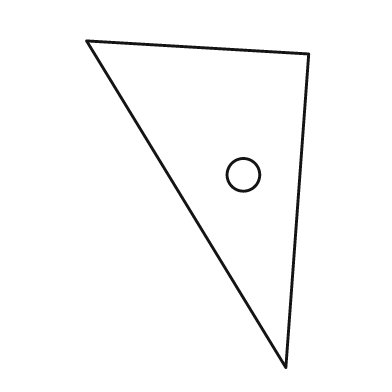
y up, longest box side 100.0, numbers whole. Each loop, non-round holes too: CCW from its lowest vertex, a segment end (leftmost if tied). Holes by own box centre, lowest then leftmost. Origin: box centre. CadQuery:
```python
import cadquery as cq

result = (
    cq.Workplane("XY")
    .moveTo(27.0, -50.0)
    .lineTo(34.0, 46.0)
    .lineTo(-34.0, 50.0)
    .close()
    .moveTo(14.0, 9.0)
    .circle(5.0)
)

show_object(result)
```